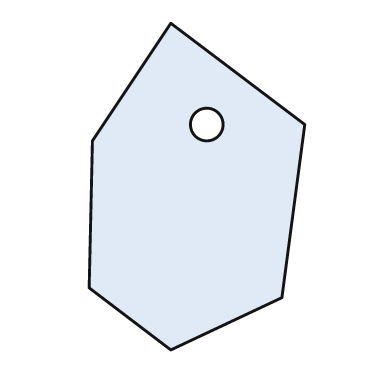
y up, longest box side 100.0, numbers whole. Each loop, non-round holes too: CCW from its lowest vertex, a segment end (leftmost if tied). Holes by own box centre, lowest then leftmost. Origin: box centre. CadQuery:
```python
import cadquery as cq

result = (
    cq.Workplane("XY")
    .moveTo(-8.0, -50.0)
    .lineTo(26.0, -34.0)
    .lineTo(33.0, 19.0)
    .lineTo(-8.0, 50.0)
    .lineTo(-32.0, 14.0)
    .lineTo(-33.0, -31.0)
    .close()
    .moveTo(3.0, 19.0)
    .circle(5.0)
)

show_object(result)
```